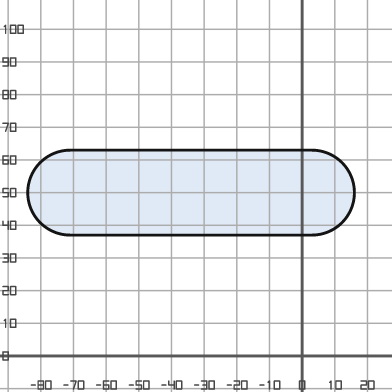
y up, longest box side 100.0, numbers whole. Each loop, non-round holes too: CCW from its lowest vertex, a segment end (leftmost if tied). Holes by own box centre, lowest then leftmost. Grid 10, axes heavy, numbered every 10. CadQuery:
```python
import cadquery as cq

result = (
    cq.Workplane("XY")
    .moveTo(-71.0, 37.0)
    .lineTo(3.0, 37.0)
    .threePointArc((16.0, 50.0), (3.0, 63.0))
    .lineTo(-71.0, 63.0)
    .threePointArc((-84.0, 50.0), (-71.0, 37.0))
    .close()
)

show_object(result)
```